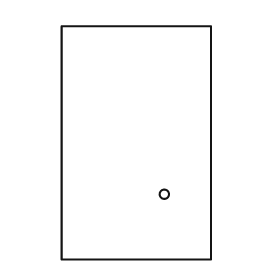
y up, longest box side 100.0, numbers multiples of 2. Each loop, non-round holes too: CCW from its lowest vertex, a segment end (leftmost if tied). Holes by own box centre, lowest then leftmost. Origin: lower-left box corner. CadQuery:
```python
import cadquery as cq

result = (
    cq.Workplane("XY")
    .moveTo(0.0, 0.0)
    .lineTo(64.0, 0.0)
    .lineTo(64.0, 100.0)
    .lineTo(0.0, 100.0)
    .close()
    .moveTo(44.0, 28.0)
    .circle(2.0)
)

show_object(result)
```